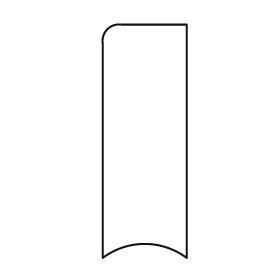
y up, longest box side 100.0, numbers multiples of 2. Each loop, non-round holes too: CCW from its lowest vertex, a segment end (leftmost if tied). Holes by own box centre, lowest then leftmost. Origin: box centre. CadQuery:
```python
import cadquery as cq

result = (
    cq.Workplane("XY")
    .moveTo(-18.0, -50.0)
    .threePointArc((0.0, -44.0), (18.0, -50.0))
    .lineTo(18.0, 50.0)
    .lineTo(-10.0, 50.0)
    .threePointArc((-16.0, 48.0), (-18.0, 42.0))
    .close()
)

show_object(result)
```